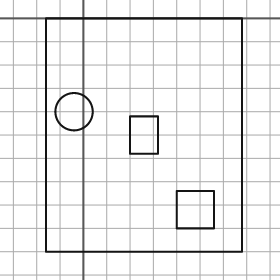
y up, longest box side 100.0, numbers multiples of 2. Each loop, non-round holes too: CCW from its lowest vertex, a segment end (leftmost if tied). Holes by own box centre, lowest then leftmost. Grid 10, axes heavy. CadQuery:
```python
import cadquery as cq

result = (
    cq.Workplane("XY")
    .moveTo(-16.0, -100.0)
    .lineTo(68.0, -100.0)
    .lineTo(68.0, 0.0)
    .lineTo(-16.0, 0.0)
    .close()
    .moveTo(40.0, -90.0)
    .lineTo(56.0, -90.0)
    .lineTo(56.0, -74.0)
    .lineTo(40.0, -74.0)
    .close()
    .moveTo(20.0, -58.0)
    .lineTo(32.0, -58.0)
    .lineTo(32.0, -42.0)
    .lineTo(20.0, -42.0)
    .close()
    .moveTo(-4.0, -40.0)
    .circle(8.0)
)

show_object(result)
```